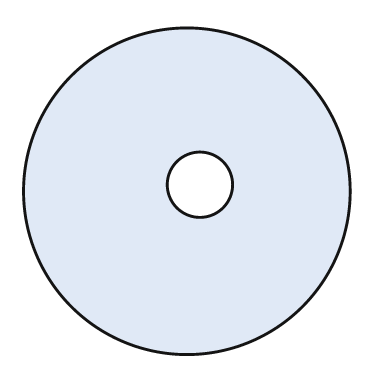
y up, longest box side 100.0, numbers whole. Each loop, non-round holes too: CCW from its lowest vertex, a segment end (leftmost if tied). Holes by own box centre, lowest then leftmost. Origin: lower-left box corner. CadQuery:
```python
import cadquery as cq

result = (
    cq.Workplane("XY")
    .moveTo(50.0, 50.0)
    .circle(50.0)
    .moveTo(54.0, 52.0)
    .circle(10.0)
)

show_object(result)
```